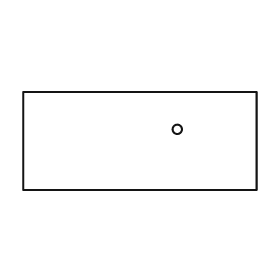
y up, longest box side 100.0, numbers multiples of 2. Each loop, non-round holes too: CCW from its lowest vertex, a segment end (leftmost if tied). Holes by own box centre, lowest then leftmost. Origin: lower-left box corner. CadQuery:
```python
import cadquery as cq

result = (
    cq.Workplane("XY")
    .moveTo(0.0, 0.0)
    .lineTo(100.0, 0.0)
    .lineTo(100.0, 42.0)
    .lineTo(0.0, 42.0)
    .close()
    .moveTo(66.0, 26.0)
    .circle(2.0)
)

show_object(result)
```